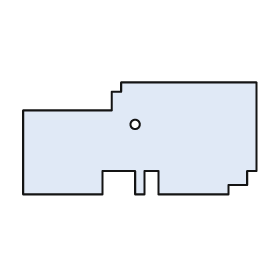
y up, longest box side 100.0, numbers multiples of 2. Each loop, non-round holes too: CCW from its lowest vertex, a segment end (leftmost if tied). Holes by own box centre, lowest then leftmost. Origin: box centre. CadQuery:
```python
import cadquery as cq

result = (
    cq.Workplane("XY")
    .moveTo(-50.0, -24.0)
    .lineTo(-16.0, -24.0)
    .lineTo(-16.0, -14.0)
    .lineTo(-2.0, -14.0)
    .lineTo(-2.0, -24.0)
    .lineTo(2.0, -24.0)
    .lineTo(2.0, -14.0)
    .lineTo(8.0, -14.0)
    .lineTo(8.0, -24.0)
    .lineTo(38.0, -24.0)
    .lineTo(38.0, -20.0)
    .lineTo(46.0, -20.0)
    .lineTo(46.0, -14.0)
    .lineTo(50.0, -14.0)
    .lineTo(50.0, 24.0)
    .lineTo(-8.0, 24.0)
    .lineTo(-8.0, 20.0)
    .lineTo(-12.0, 20.0)
    .lineTo(-12.0, 12.0)
    .lineTo(-50.0, 12.0)
    .close()
    .moveTo(-2.0, 6.0)
    .circle(2.0)
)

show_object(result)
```